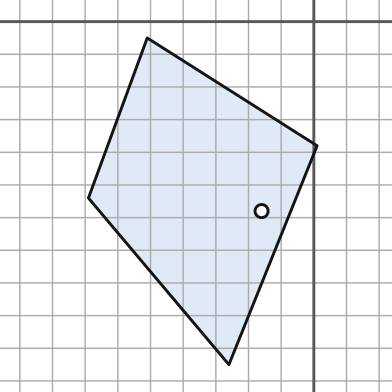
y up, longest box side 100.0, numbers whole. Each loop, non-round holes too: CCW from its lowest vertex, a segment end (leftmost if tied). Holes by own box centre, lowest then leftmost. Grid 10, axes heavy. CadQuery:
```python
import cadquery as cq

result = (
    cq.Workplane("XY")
    .moveTo(-26.0, -105.0)
    .lineTo(1.0, -38.0)
    .lineTo(-51.0, -5.0)
    .lineTo(-69.0, -54.0)
    .close()
    .moveTo(-16.0, -58.0)
    .circle(2.0)
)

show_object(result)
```